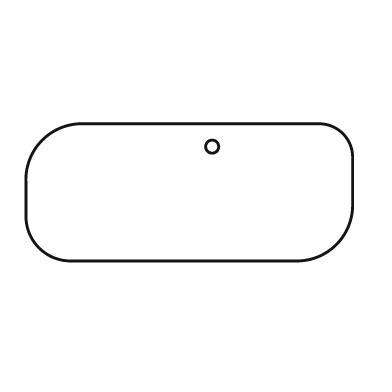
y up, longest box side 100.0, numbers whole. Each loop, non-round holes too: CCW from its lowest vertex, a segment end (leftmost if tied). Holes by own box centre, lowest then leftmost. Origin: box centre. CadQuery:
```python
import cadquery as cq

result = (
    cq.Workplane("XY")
    .moveTo(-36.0, -21.0)
    .lineTo(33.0, -21.0)
    .threePointArc((45.0, -16.0), (50.0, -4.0))
    .lineTo(50.0, 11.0)
    .threePointArc((47.0, 18.0), (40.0, 21.0))
    .lineTo(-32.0, 21.0)
    .threePointArc((-45.0, 16.0), (-50.0, 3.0))
    .lineTo(-50.0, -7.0)
    .threePointArc((-46.0, -17.0), (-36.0, -21.0))
    .close()
    .moveTo(7.0, 14.0)
    .circle(2.0)
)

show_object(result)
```